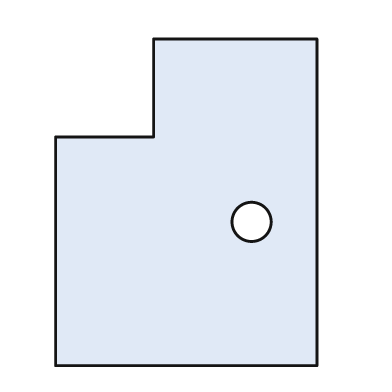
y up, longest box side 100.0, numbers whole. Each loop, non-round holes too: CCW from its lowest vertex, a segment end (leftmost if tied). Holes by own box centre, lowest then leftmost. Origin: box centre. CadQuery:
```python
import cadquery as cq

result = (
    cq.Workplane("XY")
    .moveTo(-40.0, -50.0)
    .lineTo(40.0, -50.0)
    .lineTo(40.0, 50.0)
    .lineTo(-10.0, 50.0)
    .lineTo(-10.0, 20.0)
    .lineTo(-40.0, 20.0)
    .close()
    .moveTo(20.0, -6.0)
    .circle(6.0)
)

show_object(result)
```